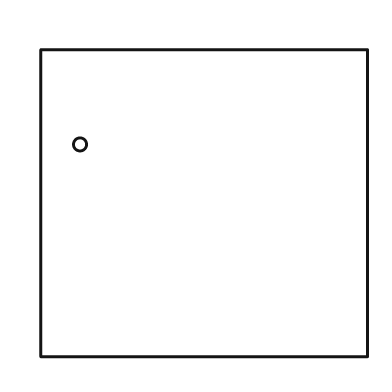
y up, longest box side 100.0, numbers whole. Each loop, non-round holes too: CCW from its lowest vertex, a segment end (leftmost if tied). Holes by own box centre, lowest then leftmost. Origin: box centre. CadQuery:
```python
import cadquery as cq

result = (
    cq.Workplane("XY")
    .moveTo(-50.0, -47.0)
    .lineTo(50.0, -47.0)
    .lineTo(50.0, 47.0)
    .lineTo(-50.0, 47.0)
    .close()
    .moveTo(-38.0, 18.0)
    .circle(2.0)
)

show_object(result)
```